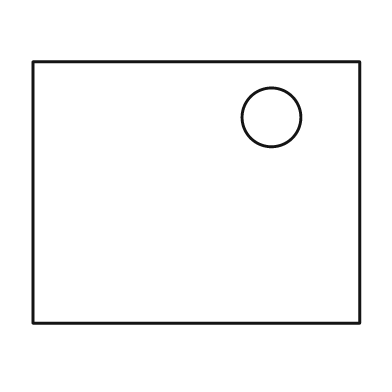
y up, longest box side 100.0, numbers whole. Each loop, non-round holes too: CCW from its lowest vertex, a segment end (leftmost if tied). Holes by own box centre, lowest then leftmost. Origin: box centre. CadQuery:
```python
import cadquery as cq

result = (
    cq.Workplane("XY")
    .moveTo(-50.0, -40.0)
    .lineTo(50.0, -40.0)
    .lineTo(50.0, 40.0)
    .lineTo(-50.0, 40.0)
    .close()
    .moveTo(23.0, 23.0)
    .circle(9.0)
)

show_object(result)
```